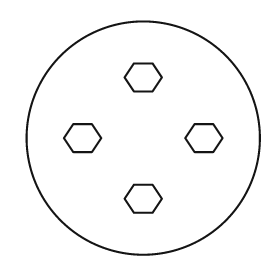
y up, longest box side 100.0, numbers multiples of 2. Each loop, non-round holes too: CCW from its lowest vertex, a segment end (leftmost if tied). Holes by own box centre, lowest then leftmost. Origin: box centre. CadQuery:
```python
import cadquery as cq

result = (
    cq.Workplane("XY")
    .moveTo(0.0, 0.0)
    .circle(50.0)
    .moveTo(-4.0, -32.0)
    .lineTo(4.0, -32.0)
    .lineTo(8.0, -26.0)
    .lineTo(4.0, -20.0)
    .lineTo(-4.0, -20.0)
    .lineTo(-8.0, -26.0)
    .close()
    .moveTo(-30.0, -6.0)
    .lineTo(-22.0, -6.0)
    .lineTo(-18.0, 0.0)
    .lineTo(-22.0, 6.0)
    .lineTo(-30.0, 6.0)
    .lineTo(-34.0, 0.0)
    .close()
    .moveTo(22.0, -6.0)
    .lineTo(30.0, -6.0)
    .lineTo(34.0, 0.0)
    .lineTo(30.0, 6.0)
    .lineTo(22.0, 6.0)
    .lineTo(18.0, 0.0)
    .close()
    .moveTo(-4.0, 20.0)
    .lineTo(4.0, 20.0)
    .lineTo(8.0, 26.0)
    .lineTo(4.0, 32.0)
    .lineTo(-4.0, 32.0)
    .lineTo(-8.0, 26.0)
    .close()
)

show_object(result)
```